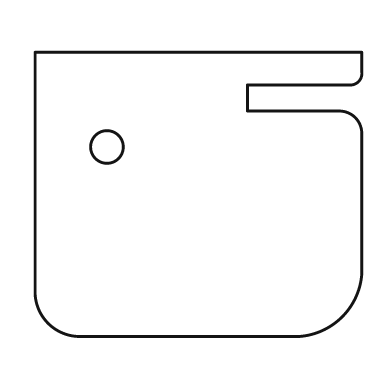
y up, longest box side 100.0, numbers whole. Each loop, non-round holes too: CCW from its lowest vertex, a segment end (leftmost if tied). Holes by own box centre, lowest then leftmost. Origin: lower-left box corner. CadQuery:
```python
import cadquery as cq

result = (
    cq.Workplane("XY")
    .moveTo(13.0, 0.0)
    .lineTo(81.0, 0.0)
    .threePointArc((94.0, 6.0), (100.0, 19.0))
    .lineTo(100.0, 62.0)
    .threePointArc((98.0, 67.0), (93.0, 69.0))
    .lineTo(65.0, 69.0)
    .lineTo(65.0, 77.0)
    .lineTo(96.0, 77.0)
    .threePointArc((99.0, 78.0), (100.0, 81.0))
    .lineTo(100.0, 87.0)
    .lineTo(0.0, 87.0)
    .lineTo(0.0, 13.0)
    .threePointArc((4.0, 4.0), (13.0, 0.0))
    .close()
    .moveTo(22.0, 58.0)
    .circle(5.0)
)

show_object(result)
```